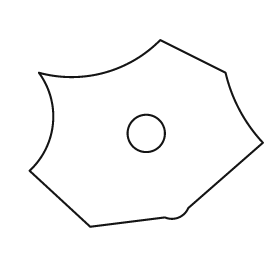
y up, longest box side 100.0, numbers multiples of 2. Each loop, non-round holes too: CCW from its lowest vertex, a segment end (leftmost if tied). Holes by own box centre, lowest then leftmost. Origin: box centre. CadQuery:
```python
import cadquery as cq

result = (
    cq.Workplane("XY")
    .moveTo(-24.0, -40.0)
    .lineTo(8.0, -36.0)
    .threePointArc((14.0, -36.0), (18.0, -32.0))
    .lineTo(50.0, -4.0)
    .threePointArc((40.0, 10.0), (34.0, 26.0))
    .lineTo(6.0, 40.0)
    .threePointArc((-18.0, 26.0), (-46.0, 26.0))
    .threePointArc((-40.0, 4.0), (-50.0, -16.0))
    .close()
    .moveTo(0.0, 0.0)
    .circle(8.0)
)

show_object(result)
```